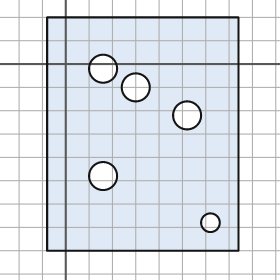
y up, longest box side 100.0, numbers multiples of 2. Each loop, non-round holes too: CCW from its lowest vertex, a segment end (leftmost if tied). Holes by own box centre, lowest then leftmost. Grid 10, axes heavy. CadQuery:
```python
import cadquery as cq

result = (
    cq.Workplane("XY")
    .moveTo(-8.0, -80.0)
    .lineTo(74.0, -80.0)
    .lineTo(74.0, 20.0)
    .lineTo(-8.0, 20.0)
    .close()
    .moveTo(62.0, -68.0)
    .circle(4.0)
    .moveTo(16.0, -48.0)
    .circle(6.0)
    .moveTo(52.0, -22.0)
    .circle(6.0)
    .moveTo(30.0, -10.0)
    .circle(6.0)
    .moveTo(16.0, -2.0)
    .circle(6.0)
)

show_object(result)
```